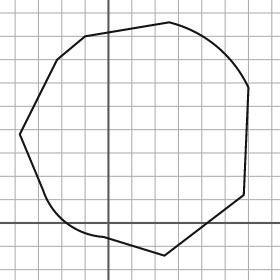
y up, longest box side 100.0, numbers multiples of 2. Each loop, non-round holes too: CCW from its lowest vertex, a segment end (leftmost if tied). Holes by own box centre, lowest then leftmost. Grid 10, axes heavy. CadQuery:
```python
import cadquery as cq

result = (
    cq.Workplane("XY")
    .moveTo(24.0, -14.0)
    .lineTo(58.0, 12.0)
    .lineTo(60.0, 58.0)
    .threePointArc((46.0, 76.0), (26.0, 86.0))
    .lineTo(-10.0, 80.0)
    .lineTo(-22.0, 70.0)
    .lineTo(-38.0, 38.0)
    .lineTo(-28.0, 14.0)
    .threePointArc((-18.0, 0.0), (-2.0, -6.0))
    .close()
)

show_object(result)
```